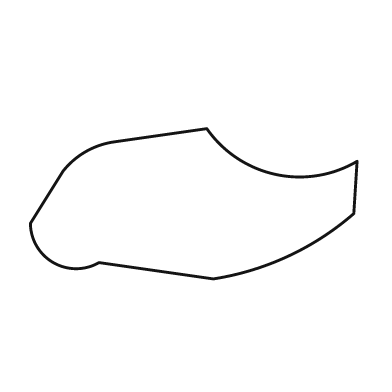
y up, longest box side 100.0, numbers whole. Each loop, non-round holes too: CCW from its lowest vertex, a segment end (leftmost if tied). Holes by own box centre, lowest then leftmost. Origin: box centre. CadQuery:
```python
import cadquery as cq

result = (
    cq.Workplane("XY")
    .moveTo(6.0, -23.0)
    .threePointArc((29.0, -16.0), (49.0, -3.0))
    .lineTo(50.0, 13.0)
    .threePointArc((25.0, 9.0), (4.0, 23.0))
    .lineTo(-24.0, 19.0)
    .threePointArc((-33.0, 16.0), (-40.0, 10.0))
    .lineTo(-50.0, -6.0)
    .threePointArc((-43.0, -18.0), (-29.0, -18.0))
    .close()
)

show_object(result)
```